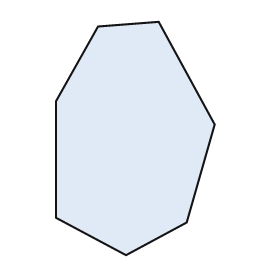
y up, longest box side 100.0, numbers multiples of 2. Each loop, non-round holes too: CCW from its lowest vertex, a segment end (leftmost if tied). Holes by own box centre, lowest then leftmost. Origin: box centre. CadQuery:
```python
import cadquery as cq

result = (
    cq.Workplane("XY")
    .moveTo(-4.0, -50.0)
    .lineTo(22.0, -36.0)
    .lineTo(34.0, 6.0)
    .lineTo(10.0, 50.0)
    .lineTo(-16.0, 48.0)
    .lineTo(-34.0, 16.0)
    .lineTo(-34.0, -34.0)
    .close()
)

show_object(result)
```